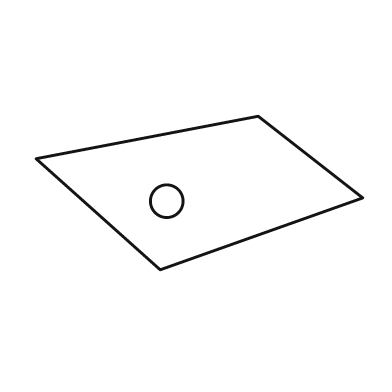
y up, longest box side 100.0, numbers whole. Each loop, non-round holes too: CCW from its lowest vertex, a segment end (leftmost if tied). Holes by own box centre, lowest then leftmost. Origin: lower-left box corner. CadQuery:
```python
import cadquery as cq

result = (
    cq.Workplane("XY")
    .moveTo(38.0, 0.0)
    .lineTo(100.0, 22.0)
    .lineTo(68.0, 47.0)
    .lineTo(0.0, 34.0)
    .close()
    .moveTo(40.0, 21.0)
    .circle(5.0)
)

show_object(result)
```